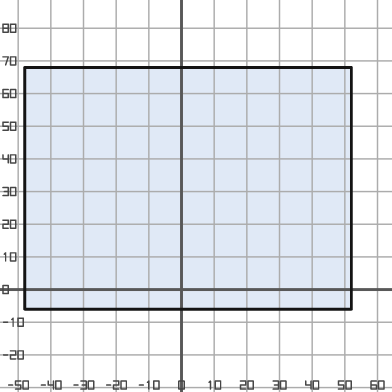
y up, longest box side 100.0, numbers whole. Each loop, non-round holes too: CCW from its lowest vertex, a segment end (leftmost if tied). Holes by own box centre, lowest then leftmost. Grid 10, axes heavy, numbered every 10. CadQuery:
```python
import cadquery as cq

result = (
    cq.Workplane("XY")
    .moveTo(-48.0, -6.0)
    .lineTo(52.0, -6.0)
    .lineTo(52.0, 68.0)
    .lineTo(-48.0, 68.0)
    .close()
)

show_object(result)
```